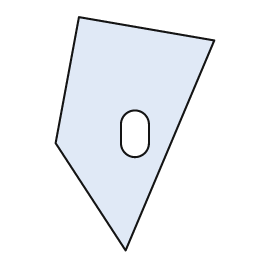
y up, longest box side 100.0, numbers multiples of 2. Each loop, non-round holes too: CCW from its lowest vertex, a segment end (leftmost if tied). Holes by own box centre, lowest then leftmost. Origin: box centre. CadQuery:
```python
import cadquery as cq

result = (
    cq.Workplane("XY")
    .moveTo(-4.0, -50.0)
    .lineTo(34.0, 40.0)
    .lineTo(-24.0, 50.0)
    .lineTo(-34.0, -4.0)
    .close()
    .moveTo(-6.0, -4.0)
    .threePointArc((0.0, -10.0), (6.0, -4.0))
    .lineTo(6.0, 4.0)
    .threePointArc((0.0, 10.0), (-6.0, 4.0))
    .close()
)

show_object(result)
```